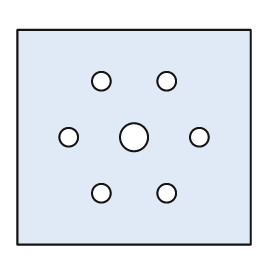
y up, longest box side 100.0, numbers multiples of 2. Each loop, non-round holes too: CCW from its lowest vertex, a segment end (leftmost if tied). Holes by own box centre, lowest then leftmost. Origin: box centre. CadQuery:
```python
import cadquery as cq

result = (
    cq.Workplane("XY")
    .moveTo(-50.0, -46.0)
    .lineTo(50.0, -46.0)
    .lineTo(50.0, 46.0)
    .lineTo(-50.0, 46.0)
    .close()
    .moveTo(-14.0, -24.0)
    .circle(4.0)
    .moveTo(14.0, -24.0)
    .circle(4.0)
    .moveTo(-28.0, 0.0)
    .circle(4.0)
    .moveTo(0.0, 0.0)
    .circle(6.0)
    .moveTo(28.0, 0.0)
    .circle(4.0)
    .moveTo(-14.0, 24.0)
    .circle(4.0)
    .moveTo(14.0, 24.0)
    .circle(4.0)
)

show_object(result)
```